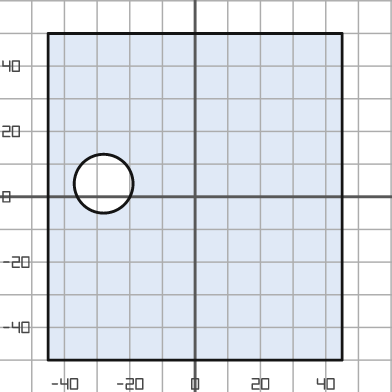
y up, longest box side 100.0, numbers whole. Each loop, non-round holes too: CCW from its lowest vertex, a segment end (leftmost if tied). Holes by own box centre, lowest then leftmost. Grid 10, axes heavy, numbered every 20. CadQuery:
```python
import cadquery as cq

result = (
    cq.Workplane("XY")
    .moveTo(-45.0, -50.0)
    .lineTo(45.0, -50.0)
    .lineTo(45.0, 50.0)
    .lineTo(-45.0, 50.0)
    .close()
    .moveTo(-28.0, 4.0)
    .circle(9.0)
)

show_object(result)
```